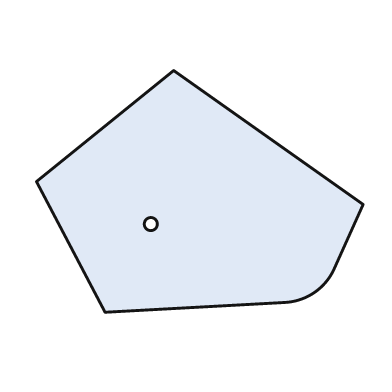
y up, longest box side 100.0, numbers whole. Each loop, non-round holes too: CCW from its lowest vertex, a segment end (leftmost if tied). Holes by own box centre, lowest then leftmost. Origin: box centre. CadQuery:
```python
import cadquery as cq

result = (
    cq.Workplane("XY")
    .moveTo(-29.0, -37.0)
    .lineTo(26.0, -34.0)
    .threePointArc((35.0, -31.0), (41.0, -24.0))
    .lineTo(50.0, -4.0)
    .lineTo(-8.0, 37.0)
    .lineTo(-50.0, 3.0)
    .close()
    .moveTo(-15.0, -10.0)
    .circle(2.0)
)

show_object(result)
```